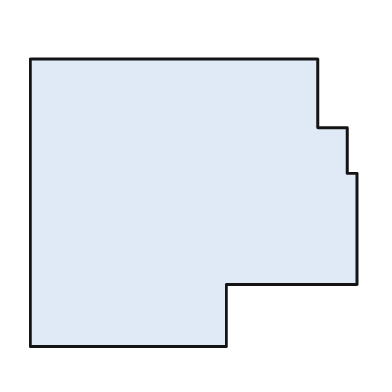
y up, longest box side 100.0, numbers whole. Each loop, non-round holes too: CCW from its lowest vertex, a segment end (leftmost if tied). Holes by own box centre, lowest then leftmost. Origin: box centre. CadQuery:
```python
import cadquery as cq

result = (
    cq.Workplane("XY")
    .moveTo(-50.0, -44.0)
    .lineTo(10.0, -44.0)
    .lineTo(10.0, -25.0)
    .lineTo(50.0, -25.0)
    .lineTo(50.0, 9.0)
    .lineTo(47.0, 9.0)
    .lineTo(47.0, 23.0)
    .lineTo(38.0, 23.0)
    .lineTo(38.0, 44.0)
    .lineTo(-50.0, 44.0)
    .close()
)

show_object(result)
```